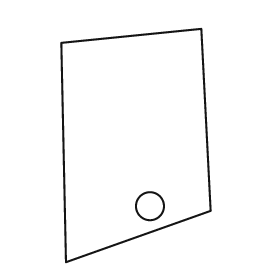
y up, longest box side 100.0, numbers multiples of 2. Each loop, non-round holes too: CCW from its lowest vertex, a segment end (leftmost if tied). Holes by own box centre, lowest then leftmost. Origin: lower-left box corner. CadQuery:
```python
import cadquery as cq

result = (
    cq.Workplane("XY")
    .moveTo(2.0, 0.0)
    .lineTo(64.0, 22.0)
    .lineTo(60.0, 100.0)
    .lineTo(0.0, 94.0)
    .close()
    .moveTo(38.0, 24.0)
    .circle(6.0)
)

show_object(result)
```